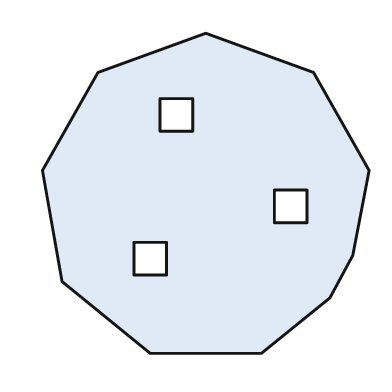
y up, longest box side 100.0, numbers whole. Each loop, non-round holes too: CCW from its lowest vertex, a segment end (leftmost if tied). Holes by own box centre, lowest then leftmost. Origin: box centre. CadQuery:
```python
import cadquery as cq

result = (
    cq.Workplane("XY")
    .moveTo(-17.0, -49.0)
    .lineTo(17.0, -49.0)
    .lineTo(38.0, -32.0)
    .lineTo(45.0, -19.0)
    .lineTo(50.0, 7.0)
    .lineTo(33.0, 37.0)
    .lineTo(0.0, 49.0)
    .lineTo(-33.0, 37.0)
    .lineTo(-50.0, 7.0)
    .lineTo(-44.0, -27.0)
    .close()
    .moveTo(-22.0, -25.0)
    .lineTo(-12.0, -25.0)
    .lineTo(-12.0, -15.0)
    .lineTo(-22.0, -15.0)
    .close()
    .moveTo(21.0, -9.0)
    .lineTo(31.0, -9.0)
    .lineTo(31.0, 1.0)
    .lineTo(21.0, 1.0)
    .close()
    .moveTo(-14.0, 19.0)
    .lineTo(-4.0, 19.0)
    .lineTo(-4.0, 29.0)
    .lineTo(-14.0, 29.0)
    .close()
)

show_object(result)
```